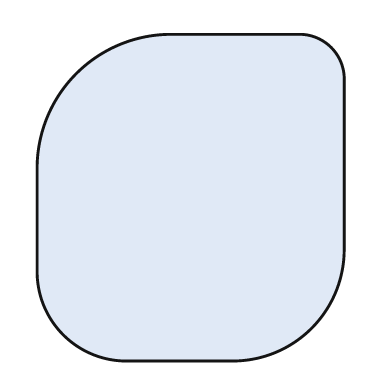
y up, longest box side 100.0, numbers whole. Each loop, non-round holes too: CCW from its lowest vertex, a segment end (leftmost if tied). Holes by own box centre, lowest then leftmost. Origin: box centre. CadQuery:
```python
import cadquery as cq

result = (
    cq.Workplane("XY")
    .moveTo(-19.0, -50.0)
    .lineTo(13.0, -50.0)
    .threePointArc((37.0, -40.0), (47.0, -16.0))
    .lineTo(47.0, 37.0)
    .threePointArc((43.0, 46.0), (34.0, 50.0))
    .lineTo(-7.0, 50.0)
    .threePointArc((-35.0, 38.0), (-47.0, 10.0))
    .lineTo(-47.0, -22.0)
    .threePointArc((-39.0, -42.0), (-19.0, -50.0))
    .close()
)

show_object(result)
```